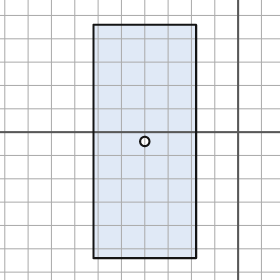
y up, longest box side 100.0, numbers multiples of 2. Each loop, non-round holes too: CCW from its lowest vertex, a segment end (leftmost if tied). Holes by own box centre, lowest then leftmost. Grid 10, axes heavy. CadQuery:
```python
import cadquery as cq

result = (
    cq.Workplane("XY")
    .moveTo(-62.0, -54.0)
    .lineTo(-18.0, -54.0)
    .lineTo(-18.0, 46.0)
    .lineTo(-62.0, 46.0)
    .close()
    .moveTo(-40.0, -4.0)
    .circle(2.0)
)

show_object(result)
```